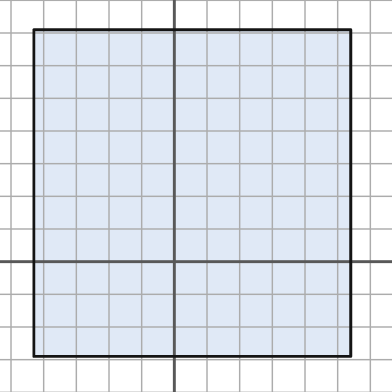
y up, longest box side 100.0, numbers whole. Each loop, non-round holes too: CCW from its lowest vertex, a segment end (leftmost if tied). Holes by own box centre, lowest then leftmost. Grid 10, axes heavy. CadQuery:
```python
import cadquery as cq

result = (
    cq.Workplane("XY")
    .moveTo(-43.0, -29.0)
    .lineTo(54.0, -29.0)
    .lineTo(54.0, 71.0)
    .lineTo(-43.0, 71.0)
    .close()
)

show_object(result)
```